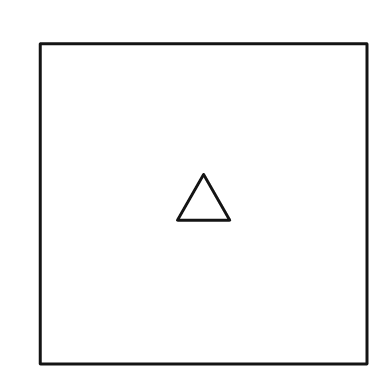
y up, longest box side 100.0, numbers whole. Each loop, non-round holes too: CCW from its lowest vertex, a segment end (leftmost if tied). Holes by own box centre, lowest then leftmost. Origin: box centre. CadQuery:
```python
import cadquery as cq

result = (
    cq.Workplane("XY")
    .moveTo(-50.0, -49.0)
    .lineTo(50.0, -49.0)
    .lineTo(50.0, 49.0)
    .lineTo(-50.0, 49.0)
    .close()
    .moveTo(-8.0, -5.0)
    .lineTo(8.0, -5.0)
    .lineTo(0.0, 9.0)
    .close()
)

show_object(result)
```